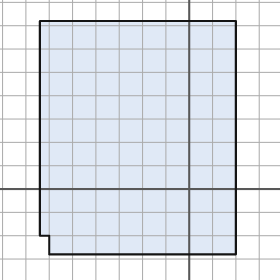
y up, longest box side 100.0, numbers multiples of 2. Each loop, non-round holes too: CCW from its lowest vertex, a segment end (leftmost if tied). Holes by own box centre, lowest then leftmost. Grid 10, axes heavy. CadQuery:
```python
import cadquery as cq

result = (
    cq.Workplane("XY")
    .moveTo(-60.0, -28.0)
    .lineTo(20.0, -28.0)
    .lineTo(20.0, 72.0)
    .lineTo(-64.0, 72.0)
    .lineTo(-64.0, -20.0)
    .lineTo(-60.0, -20.0)
    .close()
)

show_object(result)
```